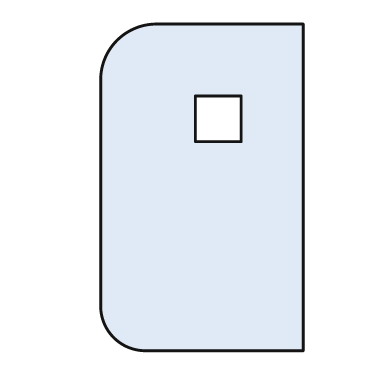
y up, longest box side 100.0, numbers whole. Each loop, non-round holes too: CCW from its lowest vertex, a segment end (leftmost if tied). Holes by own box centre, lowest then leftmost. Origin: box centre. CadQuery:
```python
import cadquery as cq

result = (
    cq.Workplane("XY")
    .moveTo(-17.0, -50.0)
    .lineTo(31.0, -50.0)
    .lineTo(31.0, 50.0)
    .lineTo(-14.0, 50.0)
    .threePointArc((-26.0, 45.0), (-31.0, 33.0))
    .lineTo(-31.0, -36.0)
    .threePointArc((-27.0, -46.0), (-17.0, -50.0))
    .close()
    .moveTo(-2.0, 14.0)
    .lineTo(12.0, 14.0)
    .lineTo(12.0, 28.0)
    .lineTo(-2.0, 28.0)
    .close()
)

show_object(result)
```